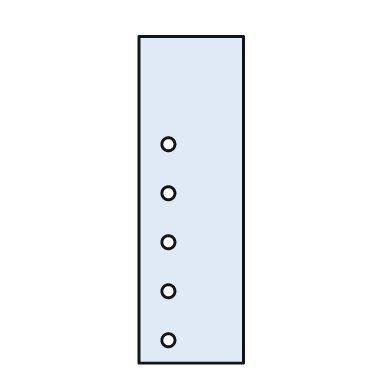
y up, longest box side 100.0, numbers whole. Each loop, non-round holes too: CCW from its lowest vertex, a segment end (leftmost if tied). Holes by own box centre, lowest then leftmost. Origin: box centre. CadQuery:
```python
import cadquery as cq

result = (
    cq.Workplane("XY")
    .moveTo(-16.0, -50.0)
    .lineTo(16.0, -50.0)
    .lineTo(16.0, 50.0)
    .lineTo(-16.0, 50.0)
    .close()
    .moveTo(-7.0, -43.0)
    .circle(2.0)
    .moveTo(-7.0, -28.0)
    .circle(2.0)
    .moveTo(-7.0, -13.0)
    .circle(2.0)
    .moveTo(-7.0, 2.0)
    .circle(2.0)
    .moveTo(-7.0, 17.0)
    .circle(2.0)
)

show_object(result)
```